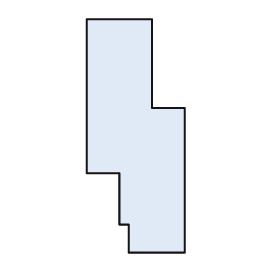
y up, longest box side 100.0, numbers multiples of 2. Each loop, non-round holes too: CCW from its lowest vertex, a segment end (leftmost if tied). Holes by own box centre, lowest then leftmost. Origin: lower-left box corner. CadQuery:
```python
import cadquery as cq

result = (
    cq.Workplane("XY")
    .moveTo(18.0, 0.0)
    .lineTo(42.0, 0.0)
    .lineTo(42.0, 62.0)
    .lineTo(28.0, 62.0)
    .lineTo(28.0, 100.0)
    .lineTo(0.0, 100.0)
    .lineTo(0.0, 34.0)
    .lineTo(14.0, 34.0)
    .lineTo(14.0, 12.0)
    .lineTo(18.0, 12.0)
    .close()
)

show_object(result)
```